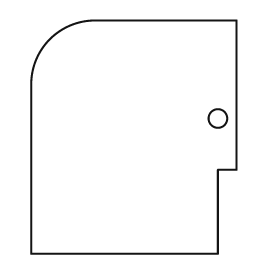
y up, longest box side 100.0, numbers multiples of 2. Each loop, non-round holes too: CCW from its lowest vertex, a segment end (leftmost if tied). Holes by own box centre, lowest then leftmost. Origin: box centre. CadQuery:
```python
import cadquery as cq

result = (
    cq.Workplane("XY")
    .moveTo(-44.0, -50.0)
    .lineTo(36.0, -50.0)
    .lineTo(36.0, -14.0)
    .lineTo(44.0, -14.0)
    .lineTo(44.0, 50.0)
    .lineTo(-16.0, 50.0)
    .threePointArc((-36.0, 42.0), (-44.0, 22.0))
    .close()
    .moveTo(36.0, 8.0)
    .circle(4.0)
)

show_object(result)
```